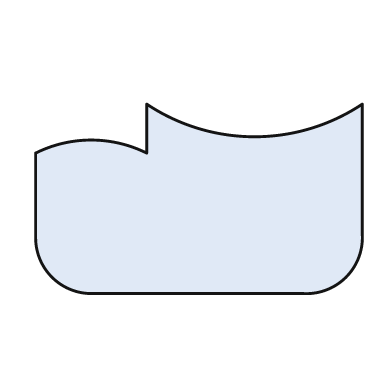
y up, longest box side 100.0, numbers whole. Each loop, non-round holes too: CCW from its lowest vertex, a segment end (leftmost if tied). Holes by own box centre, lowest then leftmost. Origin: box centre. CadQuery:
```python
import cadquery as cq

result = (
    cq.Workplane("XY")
    .moveTo(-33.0, -29.0)
    .lineTo(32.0, -29.0)
    .threePointArc((45.0, -24.0), (50.0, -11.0))
    .lineTo(50.0, 29.0)
    .threePointArc((17.0, 19.0), (-16.0, 29.0))
    .lineTo(-16.0, 14.0)
    .threePointArc((-33.0, 18.0), (-50.0, 14.0))
    .lineTo(-50.0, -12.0)
    .threePointArc((-45.0, -24.0), (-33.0, -29.0))
    .close()
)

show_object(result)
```